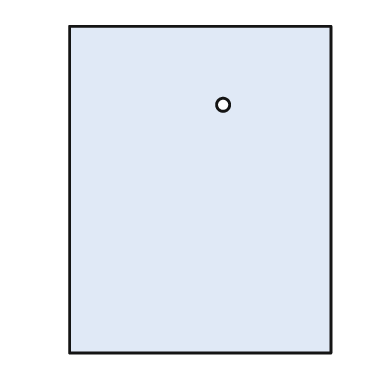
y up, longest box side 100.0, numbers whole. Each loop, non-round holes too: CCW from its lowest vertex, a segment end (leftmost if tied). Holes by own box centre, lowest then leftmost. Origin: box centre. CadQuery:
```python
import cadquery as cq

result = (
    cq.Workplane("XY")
    .moveTo(-40.0, -50.0)
    .lineTo(40.0, -50.0)
    .lineTo(40.0, 50.0)
    .lineTo(-40.0, 50.0)
    .close()
    .moveTo(7.0, 26.0)
    .circle(2.0)
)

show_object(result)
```